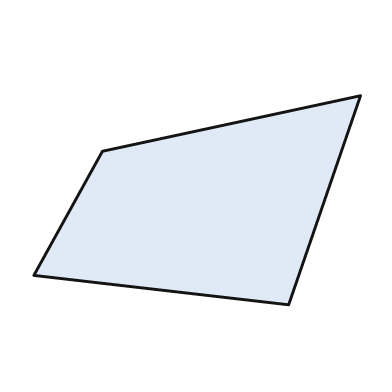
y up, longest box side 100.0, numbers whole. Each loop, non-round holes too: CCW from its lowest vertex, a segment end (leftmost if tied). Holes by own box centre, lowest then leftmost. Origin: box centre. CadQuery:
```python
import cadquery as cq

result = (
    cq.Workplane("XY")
    .moveTo(28.0, -32.0)
    .lineTo(50.0, 32.0)
    .lineTo(-29.0, 15.0)
    .lineTo(-50.0, -23.0)
    .close()
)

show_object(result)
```